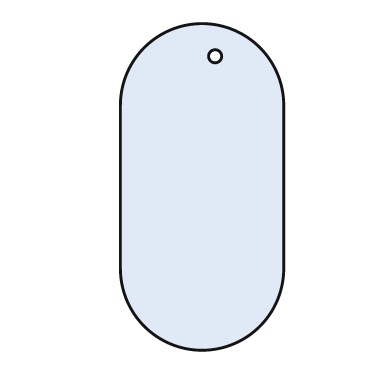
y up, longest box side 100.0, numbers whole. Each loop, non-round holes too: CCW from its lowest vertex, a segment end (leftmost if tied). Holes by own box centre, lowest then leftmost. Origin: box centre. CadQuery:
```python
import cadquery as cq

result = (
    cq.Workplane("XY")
    .moveTo(-25.0, -25.0)
    .threePointArc((0.0, -50.0), (25.0, -25.0))
    .lineTo(25.0, 25.0)
    .threePointArc((0.0, 50.0), (-25.0, 25.0))
    .close()
    .moveTo(4.0, 40.0)
    .circle(2.0)
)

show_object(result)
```